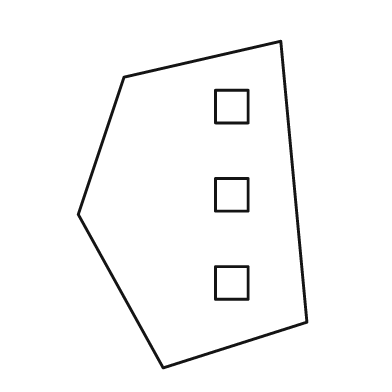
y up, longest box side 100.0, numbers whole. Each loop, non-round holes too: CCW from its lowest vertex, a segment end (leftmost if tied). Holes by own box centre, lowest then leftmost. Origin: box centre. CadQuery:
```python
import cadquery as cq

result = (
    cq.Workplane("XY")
    .moveTo(-9.0, -50.0)
    .lineTo(35.0, -36.0)
    .lineTo(27.0, 50.0)
    .lineTo(-21.0, 39.0)
    .lineTo(-35.0, -3.0)
    .close()
    .moveTo(7.0, -29.0)
    .lineTo(17.0, -29.0)
    .lineTo(17.0, -19.0)
    .lineTo(7.0, -19.0)
    .close()
    .moveTo(7.0, -2.0)
    .lineTo(17.0, -2.0)
    .lineTo(17.0, 8.0)
    .lineTo(7.0, 8.0)
    .close()
    .moveTo(7.0, 25.0)
    .lineTo(17.0, 25.0)
    .lineTo(17.0, 35.0)
    .lineTo(7.0, 35.0)
    .close()
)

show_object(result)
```